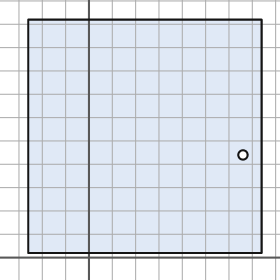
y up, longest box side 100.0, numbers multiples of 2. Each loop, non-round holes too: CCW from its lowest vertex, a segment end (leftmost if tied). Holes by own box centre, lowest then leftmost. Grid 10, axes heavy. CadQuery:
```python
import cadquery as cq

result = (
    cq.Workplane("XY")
    .moveTo(-26.0, 2.0)
    .lineTo(74.0, 2.0)
    .lineTo(74.0, 102.0)
    .lineTo(-26.0, 102.0)
    .close()
    .moveTo(66.0, 44.0)
    .circle(2.0)
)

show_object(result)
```